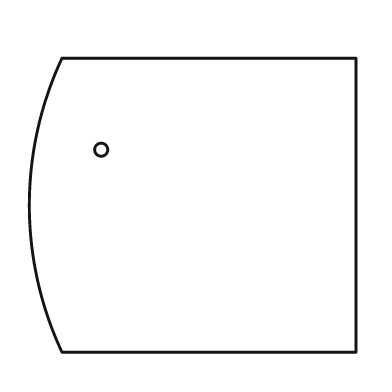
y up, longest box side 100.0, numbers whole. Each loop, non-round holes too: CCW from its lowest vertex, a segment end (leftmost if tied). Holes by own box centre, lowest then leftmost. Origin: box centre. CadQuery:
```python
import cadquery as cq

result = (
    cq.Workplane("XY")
    .moveTo(-40.0, -45.0)
    .lineTo(50.0, -45.0)
    .lineTo(50.0, 45.0)
    .lineTo(-40.0, 45.0)
    .threePointArc((-50.0, 0.0), (-40.0, -45.0))
    .close()
    .moveTo(-28.0, 17.0)
    .circle(2.0)
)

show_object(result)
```